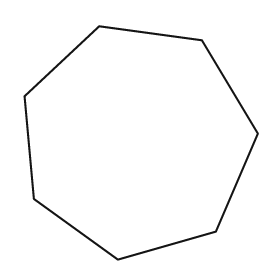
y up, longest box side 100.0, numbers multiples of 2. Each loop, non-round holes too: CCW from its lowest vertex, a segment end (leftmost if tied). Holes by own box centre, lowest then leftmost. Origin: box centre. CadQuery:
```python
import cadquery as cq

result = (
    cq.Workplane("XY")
    .moveTo(-10.0, -50.0)
    .lineTo(32.0, -38.0)
    .lineTo(50.0, 4.0)
    .lineTo(26.0, 44.0)
    .lineTo(-18.0, 50.0)
    .lineTo(-50.0, 20.0)
    .lineTo(-46.0, -24.0)
    .close()
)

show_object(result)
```